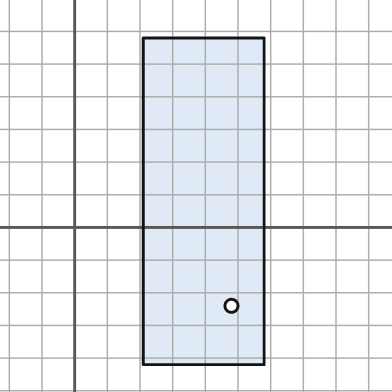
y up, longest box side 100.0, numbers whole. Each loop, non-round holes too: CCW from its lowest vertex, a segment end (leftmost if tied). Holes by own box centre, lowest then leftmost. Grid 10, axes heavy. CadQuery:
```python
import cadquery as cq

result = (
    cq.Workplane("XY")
    .moveTo(21.0, -42.0)
    .lineTo(58.0, -42.0)
    .lineTo(58.0, 58.0)
    .lineTo(21.0, 58.0)
    .close()
    .moveTo(48.0, -24.0)
    .circle(2.0)
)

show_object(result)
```